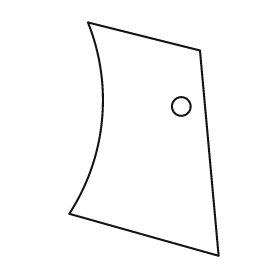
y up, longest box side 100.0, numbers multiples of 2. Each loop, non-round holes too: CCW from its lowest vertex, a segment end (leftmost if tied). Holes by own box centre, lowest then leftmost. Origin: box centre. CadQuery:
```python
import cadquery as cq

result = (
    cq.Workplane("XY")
    .moveTo(32.0, -50.0)
    .lineTo(24.0, 38.0)
    .lineTo(-24.0, 50.0)
    .threePointArc((-18.0, 8.0), (-32.0, -32.0))
    .close()
    .moveTo(16.0, 14.0)
    .circle(4.0)
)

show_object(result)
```